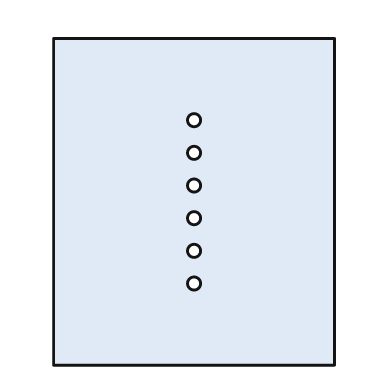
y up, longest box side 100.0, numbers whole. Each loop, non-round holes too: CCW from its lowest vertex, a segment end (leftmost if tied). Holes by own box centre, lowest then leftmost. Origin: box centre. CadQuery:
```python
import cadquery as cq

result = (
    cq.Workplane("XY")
    .moveTo(-43.0, -50.0)
    .lineTo(43.0, -50.0)
    .lineTo(43.0, 50.0)
    .lineTo(-43.0, 50.0)
    .close()
    .moveTo(0.0, -25.0)
    .circle(2.0)
    .moveTo(0.0, -15.0)
    .circle(2.0)
    .moveTo(0.0, -5.0)
    .circle(2.0)
    .moveTo(0.0, 5.0)
    .circle(2.0)
    .moveTo(0.0, 15.0)
    .circle(2.0)
    .moveTo(0.0, 25.0)
    .circle(2.0)
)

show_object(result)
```